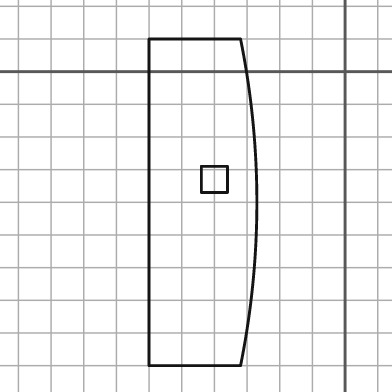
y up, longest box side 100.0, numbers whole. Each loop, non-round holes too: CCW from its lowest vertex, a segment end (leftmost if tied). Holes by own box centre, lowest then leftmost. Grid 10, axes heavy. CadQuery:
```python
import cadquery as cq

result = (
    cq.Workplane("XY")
    .moveTo(-60.0, -90.0)
    .lineTo(-32.0, -90.0)
    .threePointArc((-27.0, -40.0), (-32.0, 10.0))
    .lineTo(-60.0, 10.0)
    .close()
    .moveTo(-44.0, -37.0)
    .lineTo(-36.0, -37.0)
    .lineTo(-36.0, -29.0)
    .lineTo(-44.0, -29.0)
    .close()
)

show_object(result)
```